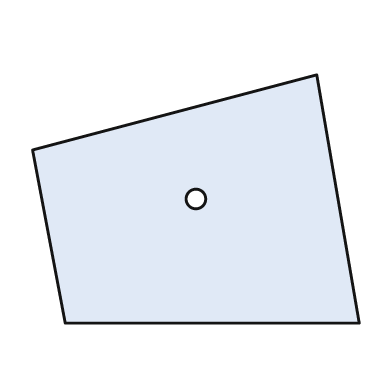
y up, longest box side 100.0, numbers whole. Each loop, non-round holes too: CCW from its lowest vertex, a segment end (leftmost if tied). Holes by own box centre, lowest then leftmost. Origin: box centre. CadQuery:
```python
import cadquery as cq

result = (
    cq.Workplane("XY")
    .moveTo(-40.0, -38.0)
    .lineTo(50.0, -38.0)
    .lineTo(37.0, 38.0)
    .lineTo(-50.0, 15.0)
    .close()
    .moveTo(0.0, 0.0)
    .circle(3.0)
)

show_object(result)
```